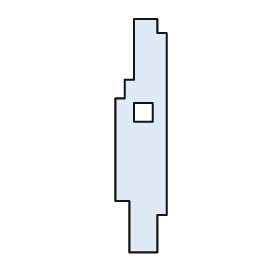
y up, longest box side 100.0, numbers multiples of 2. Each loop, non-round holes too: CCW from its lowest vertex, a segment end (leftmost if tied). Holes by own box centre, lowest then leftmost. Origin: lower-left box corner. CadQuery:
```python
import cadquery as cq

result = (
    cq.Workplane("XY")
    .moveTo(6.0, 0.0)
    .lineTo(18.0, 0.0)
    .lineTo(18.0, 16.0)
    .lineTo(22.0, 16.0)
    .lineTo(22.0, 94.0)
    .lineTo(18.0, 94.0)
    .lineTo(18.0, 100.0)
    .lineTo(8.0, 100.0)
    .lineTo(8.0, 74.0)
    .lineTo(4.0, 74.0)
    .lineTo(4.0, 66.0)
    .lineTo(0.0, 66.0)
    .lineTo(0.0, 22.0)
    .lineTo(6.0, 22.0)
    .close()
    .moveTo(8.0, 56.0)
    .lineTo(16.0, 56.0)
    .lineTo(16.0, 64.0)
    .lineTo(8.0, 64.0)
    .close()
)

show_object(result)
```